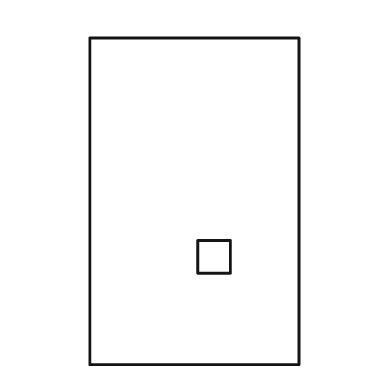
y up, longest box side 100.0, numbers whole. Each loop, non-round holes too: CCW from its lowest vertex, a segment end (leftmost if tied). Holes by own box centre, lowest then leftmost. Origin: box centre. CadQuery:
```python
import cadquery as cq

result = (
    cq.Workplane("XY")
    .moveTo(-32.0, -50.0)
    .lineTo(32.0, -50.0)
    .lineTo(32.0, 50.0)
    .lineTo(-32.0, 50.0)
    .close()
    .moveTo(1.0, -22.0)
    .lineTo(11.0, -22.0)
    .lineTo(11.0, -12.0)
    .lineTo(1.0, -12.0)
    .close()
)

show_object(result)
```